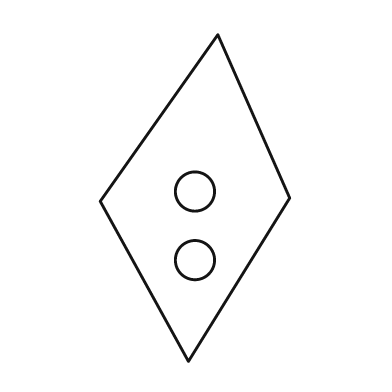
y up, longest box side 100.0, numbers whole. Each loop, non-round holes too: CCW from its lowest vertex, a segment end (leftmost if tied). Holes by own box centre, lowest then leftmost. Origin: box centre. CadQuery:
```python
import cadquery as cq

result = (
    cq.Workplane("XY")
    .moveTo(-2.0, -50.0)
    .lineTo(29.0, 0.0)
    .lineTo(7.0, 50.0)
    .lineTo(-29.0, -1.0)
    .close()
    .moveTo(0.0, -19.0)
    .circle(6.0)
    .moveTo(0.0, 2.0)
    .circle(6.0)
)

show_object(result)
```